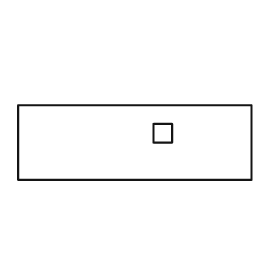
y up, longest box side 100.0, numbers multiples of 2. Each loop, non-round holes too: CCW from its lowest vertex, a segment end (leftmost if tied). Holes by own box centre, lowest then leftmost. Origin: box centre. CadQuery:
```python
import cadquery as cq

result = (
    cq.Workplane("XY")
    .moveTo(-50.0, -16.0)
    .lineTo(50.0, -16.0)
    .lineTo(50.0, 16.0)
    .lineTo(-50.0, 16.0)
    .close()
    .moveTo(8.0, 0.0)
    .lineTo(16.0, 0.0)
    .lineTo(16.0, 8.0)
    .lineTo(8.0, 8.0)
    .close()
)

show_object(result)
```